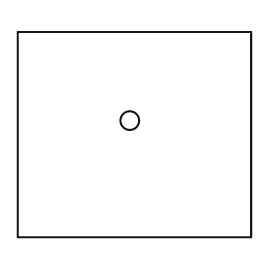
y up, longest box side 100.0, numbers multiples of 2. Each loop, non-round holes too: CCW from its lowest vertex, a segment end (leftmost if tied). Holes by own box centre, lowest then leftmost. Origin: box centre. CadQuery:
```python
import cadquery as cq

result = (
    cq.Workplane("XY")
    .moveTo(-50.0, -44.0)
    .lineTo(50.0, -44.0)
    .lineTo(50.0, 44.0)
    .lineTo(-50.0, 44.0)
    .close()
    .moveTo(-2.0, 6.0)
    .circle(4.0)
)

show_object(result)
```